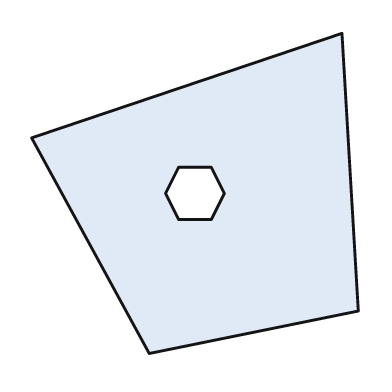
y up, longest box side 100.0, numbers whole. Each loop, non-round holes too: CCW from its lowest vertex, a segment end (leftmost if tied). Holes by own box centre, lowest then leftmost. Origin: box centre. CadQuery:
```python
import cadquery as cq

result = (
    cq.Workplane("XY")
    .moveTo(-14.0, -49.0)
    .lineTo(50.0, -36.0)
    .lineTo(45.0, 49.0)
    .lineTo(-50.0, 17.0)
    .close()
    .moveTo(-5.0, -8.0)
    .lineTo(5.0, -8.0)
    .lineTo(9.0, 0.0)
    .lineTo(5.0, 8.0)
    .lineTo(-5.0, 8.0)
    .lineTo(-9.0, 0.0)
    .close()
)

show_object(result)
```